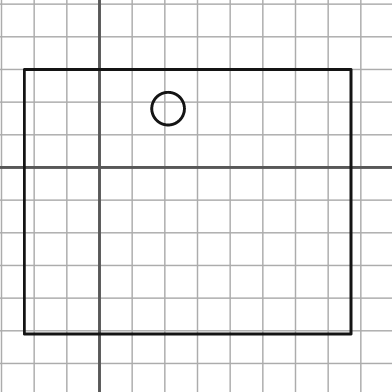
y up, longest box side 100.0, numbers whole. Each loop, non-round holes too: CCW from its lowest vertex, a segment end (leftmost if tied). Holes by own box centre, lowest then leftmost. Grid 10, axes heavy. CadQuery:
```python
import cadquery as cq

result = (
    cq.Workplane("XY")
    .moveTo(-23.0, -51.0)
    .lineTo(77.0, -51.0)
    .lineTo(77.0, 30.0)
    .lineTo(-23.0, 30.0)
    .close()
    .moveTo(21.0, 18.0)
    .circle(5.0)
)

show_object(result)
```